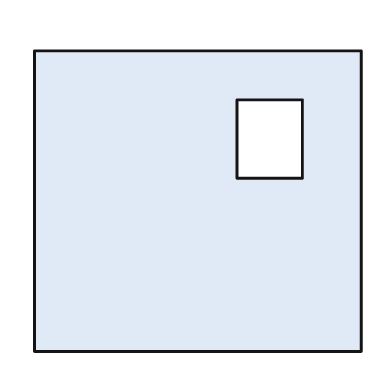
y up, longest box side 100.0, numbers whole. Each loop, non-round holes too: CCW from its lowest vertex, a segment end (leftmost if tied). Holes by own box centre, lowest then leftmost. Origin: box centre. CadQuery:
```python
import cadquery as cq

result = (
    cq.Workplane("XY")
    .moveTo(-50.0, -46.0)
    .lineTo(50.0, -46.0)
    .lineTo(50.0, 46.0)
    .lineTo(-50.0, 46.0)
    .close()
    .moveTo(12.0, 7.0)
    .lineTo(32.0, 7.0)
    .lineTo(32.0, 31.0)
    .lineTo(12.0, 31.0)
    .close()
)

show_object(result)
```